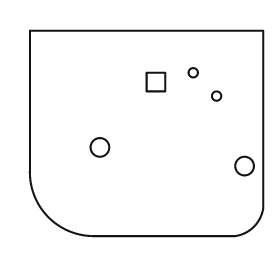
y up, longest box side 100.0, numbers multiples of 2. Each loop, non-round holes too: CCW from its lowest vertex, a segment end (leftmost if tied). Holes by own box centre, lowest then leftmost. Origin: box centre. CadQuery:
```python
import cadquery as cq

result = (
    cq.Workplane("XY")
    .moveTo(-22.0, -44.0)
    .lineTo(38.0, -44.0)
    .threePointArc((46.0, -40.0), (50.0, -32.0))
    .lineTo(50.0, 44.0)
    .lineTo(-50.0, 44.0)
    .lineTo(-50.0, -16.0)
    .threePointArc((-42.0, -36.0), (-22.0, -44.0))
    .close()
    .moveTo(42.0, -14.0)
    .circle(4.0)
    .moveTo(-20.0, -6.0)
    .circle(4.0)
    .moveTo(30.0, 16.0)
    .circle(2.0)
    .moveTo(0.0, 18.0)
    .lineTo(8.0, 18.0)
    .lineTo(8.0, 26.0)
    .lineTo(0.0, 26.0)
    .close()
    .moveTo(20.0, 26.0)
    .circle(2.0)
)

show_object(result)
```